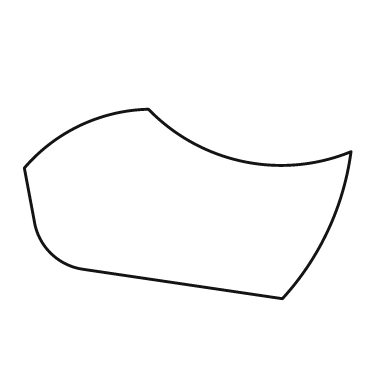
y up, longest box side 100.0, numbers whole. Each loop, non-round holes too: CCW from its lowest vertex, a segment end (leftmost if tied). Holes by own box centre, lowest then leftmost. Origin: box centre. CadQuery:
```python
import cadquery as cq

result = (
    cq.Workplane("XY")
    .moveTo(29.0, -29.0)
    .threePointArc((43.0, -8.0), (50.0, 16.0))
    .threePointArc((17.0, 13.0), (-12.0, 29.0))
    .threePointArc((-33.0, 24.0), (-50.0, 11.0))
    .lineTo(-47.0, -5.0)
    .threePointArc((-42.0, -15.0), (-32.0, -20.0))
    .close()
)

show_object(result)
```